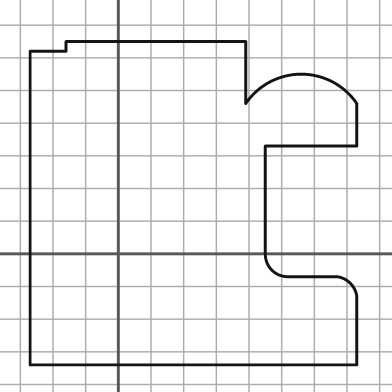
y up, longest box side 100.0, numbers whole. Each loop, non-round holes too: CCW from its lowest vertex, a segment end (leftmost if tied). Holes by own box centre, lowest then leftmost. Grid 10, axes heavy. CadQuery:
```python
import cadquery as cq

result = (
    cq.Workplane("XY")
    .moveTo(-27.0, -34.0)
    .lineTo(73.0, -34.0)
    .lineTo(73.0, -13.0)
    .threePointArc((71.0, -9.0), (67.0, -7.0))
    .lineTo(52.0, -7.0)
    .threePointArc((47.0, -5.0), (45.0, 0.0))
    .lineTo(45.0, 33.0)
    .lineTo(73.0, 33.0)
    .lineTo(73.0, 46.0)
    .threePointArc((56.0, 55.0), (39.0, 46.0))
    .lineTo(39.0, 65.0)
    .lineTo(-16.0, 65.0)
    .lineTo(-16.0, 62.0)
    .lineTo(-27.0, 62.0)
    .close()
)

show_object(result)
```